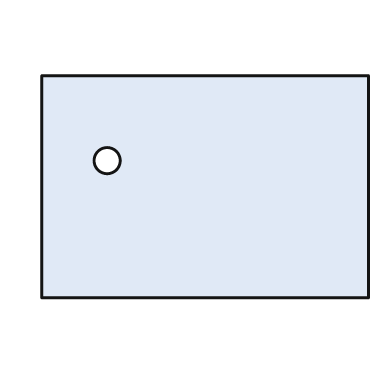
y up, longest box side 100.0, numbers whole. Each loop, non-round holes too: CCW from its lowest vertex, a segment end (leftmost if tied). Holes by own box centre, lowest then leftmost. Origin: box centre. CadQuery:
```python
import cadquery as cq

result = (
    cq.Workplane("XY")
    .moveTo(-50.0, -34.0)
    .lineTo(50.0, -34.0)
    .lineTo(50.0, 34.0)
    .lineTo(-50.0, 34.0)
    .close()
    .moveTo(-30.0, 8.0)
    .circle(4.0)
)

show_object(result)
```